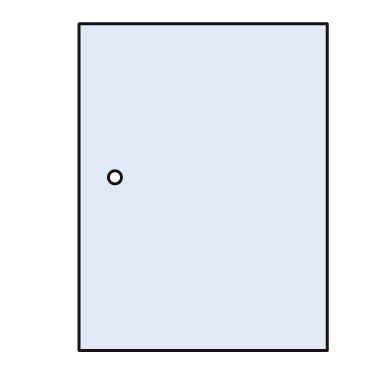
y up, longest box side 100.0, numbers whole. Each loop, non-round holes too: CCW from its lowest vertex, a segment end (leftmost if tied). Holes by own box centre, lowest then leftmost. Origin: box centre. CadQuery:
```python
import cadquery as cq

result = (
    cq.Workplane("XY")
    .moveTo(-38.0, -50.0)
    .lineTo(38.0, -50.0)
    .lineTo(38.0, 50.0)
    .lineTo(-38.0, 50.0)
    .close()
    .moveTo(-27.0, 3.0)
    .circle(2.0)
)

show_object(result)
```